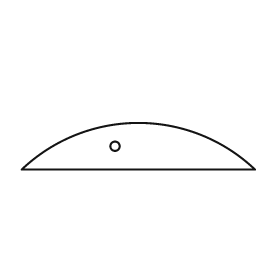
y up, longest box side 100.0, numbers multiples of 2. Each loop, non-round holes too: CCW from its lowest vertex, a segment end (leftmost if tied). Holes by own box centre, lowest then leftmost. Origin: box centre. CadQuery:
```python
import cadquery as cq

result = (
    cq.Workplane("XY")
    .moveTo(-50.0, -10.0)
    .lineTo(50.0, -10.0)
    .threePointArc((0.0, 10.0), (-50.0, -10.0))
    .close()
    .moveTo(-10.0, 0.0)
    .circle(2.0)
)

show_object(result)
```